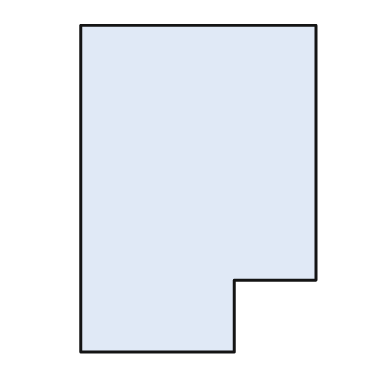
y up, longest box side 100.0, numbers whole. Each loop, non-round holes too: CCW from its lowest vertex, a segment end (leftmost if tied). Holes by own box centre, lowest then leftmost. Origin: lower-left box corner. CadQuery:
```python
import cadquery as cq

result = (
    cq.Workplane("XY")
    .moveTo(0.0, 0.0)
    .lineTo(47.0, 0.0)
    .lineTo(47.0, 22.0)
    .lineTo(72.0, 22.0)
    .lineTo(72.0, 100.0)
    .lineTo(0.0, 100.0)
    .close()
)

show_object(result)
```